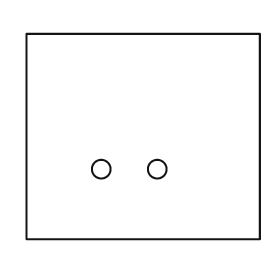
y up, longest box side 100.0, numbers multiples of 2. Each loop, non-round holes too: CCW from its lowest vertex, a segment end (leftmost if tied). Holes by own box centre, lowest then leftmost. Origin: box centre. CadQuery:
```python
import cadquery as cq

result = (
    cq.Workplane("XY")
    .moveTo(-50.0, -44.0)
    .lineTo(50.0, -44.0)
    .lineTo(50.0, 44.0)
    .lineTo(-50.0, 44.0)
    .close()
    .moveTo(-18.0, -14.0)
    .circle(4.0)
    .moveTo(6.0, -14.0)
    .circle(4.0)
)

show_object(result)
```